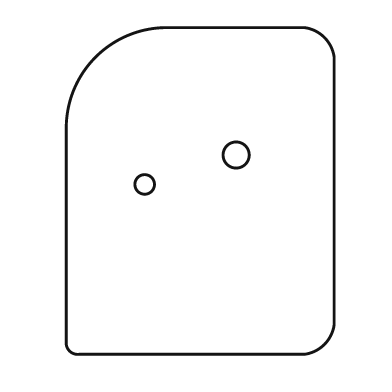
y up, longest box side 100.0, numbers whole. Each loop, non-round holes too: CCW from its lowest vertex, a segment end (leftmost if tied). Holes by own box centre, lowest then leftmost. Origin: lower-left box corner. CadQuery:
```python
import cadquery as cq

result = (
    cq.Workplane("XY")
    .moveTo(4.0, 0.0)
    .lineTo(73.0, 0.0)
    .threePointArc((79.0, 3.0), (82.0, 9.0))
    .lineTo(82.0, 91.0)
    .threePointArc((79.0, 97.0), (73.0, 100.0))
    .lineTo(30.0, 100.0)
    .threePointArc((9.0, 91.0), (0.0, 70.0))
    .lineTo(0.0, 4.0)
    .threePointArc((1.0, 1.0), (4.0, 0.0))
    .close()
    .moveTo(24.0, 52.0)
    .circle(3.0)
    .moveTo(52.0, 61.0)
    .circle(4.0)
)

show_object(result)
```